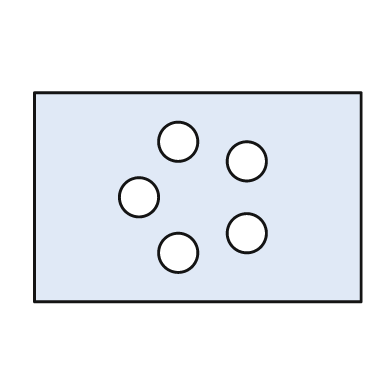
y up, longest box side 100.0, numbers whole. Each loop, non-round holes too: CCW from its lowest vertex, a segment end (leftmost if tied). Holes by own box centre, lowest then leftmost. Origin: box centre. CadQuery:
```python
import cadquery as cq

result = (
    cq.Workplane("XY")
    .moveTo(-50.0, -32.0)
    .lineTo(50.0, -32.0)
    .lineTo(50.0, 32.0)
    .lineTo(-50.0, 32.0)
    .close()
    .moveTo(-6.0, -17.0)
    .circle(6.0)
    .moveTo(15.0, -11.0)
    .circle(6.0)
    .moveTo(-18.0, 0.0)
    .circle(6.0)
    .moveTo(15.0, 11.0)
    .circle(6.0)
    .moveTo(-6.0, 17.0)
    .circle(6.0)
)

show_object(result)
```